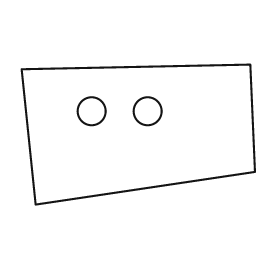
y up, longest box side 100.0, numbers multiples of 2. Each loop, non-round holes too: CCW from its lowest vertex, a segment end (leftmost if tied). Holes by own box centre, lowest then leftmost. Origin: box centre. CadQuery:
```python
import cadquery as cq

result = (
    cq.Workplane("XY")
    .moveTo(-44.0, -30.0)
    .lineTo(50.0, -16.0)
    .lineTo(48.0, 30.0)
    .lineTo(-50.0, 28.0)
    .close()
    .moveTo(-20.0, 10.0)
    .circle(6.0)
    .moveTo(4.0, 10.0)
    .circle(6.0)
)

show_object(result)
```